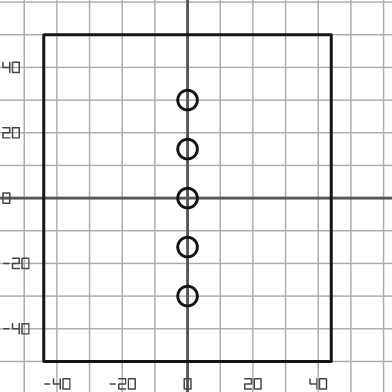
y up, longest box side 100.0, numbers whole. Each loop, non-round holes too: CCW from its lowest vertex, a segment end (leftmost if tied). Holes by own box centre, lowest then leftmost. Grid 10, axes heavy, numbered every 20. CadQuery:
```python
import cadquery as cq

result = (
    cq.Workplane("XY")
    .moveTo(-44.0, -50.0)
    .lineTo(44.0, -50.0)
    .lineTo(44.0, 50.0)
    .lineTo(-44.0, 50.0)
    .close()
    .moveTo(0.0, -30.0)
    .circle(3.0)
    .moveTo(0.0, -15.0)
    .circle(3.0)
    .moveTo(0.0, 0.0)
    .circle(3.0)
    .moveTo(0.0, 15.0)
    .circle(3.0)
    .moveTo(0.0, 30.0)
    .circle(3.0)
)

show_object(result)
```